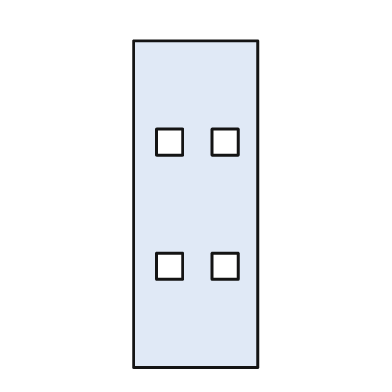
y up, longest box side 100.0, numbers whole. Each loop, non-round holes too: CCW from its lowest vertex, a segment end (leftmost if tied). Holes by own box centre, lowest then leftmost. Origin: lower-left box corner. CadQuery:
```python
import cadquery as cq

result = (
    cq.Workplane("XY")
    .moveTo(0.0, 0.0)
    .lineTo(38.0, 0.0)
    .lineTo(38.0, 100.0)
    .lineTo(0.0, 100.0)
    .close()
    .moveTo(7.0, 27.0)
    .lineTo(15.0, 27.0)
    .lineTo(15.0, 35.0)
    .lineTo(7.0, 35.0)
    .close()
    .moveTo(24.0, 27.0)
    .lineTo(32.0, 27.0)
    .lineTo(32.0, 35.0)
    .lineTo(24.0, 35.0)
    .close()
    .moveTo(7.0, 65.0)
    .lineTo(15.0, 65.0)
    .lineTo(15.0, 73.0)
    .lineTo(7.0, 73.0)
    .close()
    .moveTo(24.0, 65.0)
    .lineTo(32.0, 65.0)
    .lineTo(32.0, 73.0)
    .lineTo(24.0, 73.0)
    .close()
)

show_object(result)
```